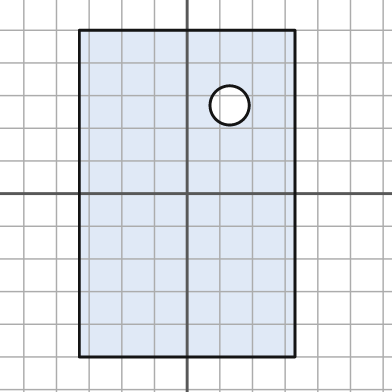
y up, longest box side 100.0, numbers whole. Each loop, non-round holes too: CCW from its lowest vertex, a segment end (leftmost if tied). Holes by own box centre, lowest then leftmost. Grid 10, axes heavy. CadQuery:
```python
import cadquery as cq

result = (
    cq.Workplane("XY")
    .moveTo(-33.0, -50.0)
    .lineTo(33.0, -50.0)
    .lineTo(33.0, 50.0)
    .lineTo(-33.0, 50.0)
    .close()
    .moveTo(13.0, 27.0)
    .circle(6.0)
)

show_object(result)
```